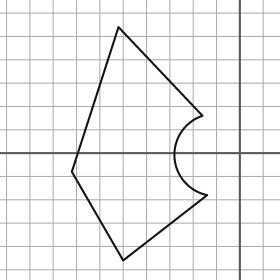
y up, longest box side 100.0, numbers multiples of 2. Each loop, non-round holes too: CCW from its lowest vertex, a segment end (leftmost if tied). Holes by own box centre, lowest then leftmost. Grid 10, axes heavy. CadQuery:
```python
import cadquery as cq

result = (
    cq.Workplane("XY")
    .moveTo(-50.0, -46.0)
    .lineTo(-14.0, -18.0)
    .threePointArc((-28.0, -2.0), (-16.0, 16.0))
    .lineTo(-52.0, 54.0)
    .lineTo(-72.0, -8.0)
    .close()
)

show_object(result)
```